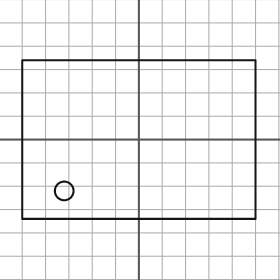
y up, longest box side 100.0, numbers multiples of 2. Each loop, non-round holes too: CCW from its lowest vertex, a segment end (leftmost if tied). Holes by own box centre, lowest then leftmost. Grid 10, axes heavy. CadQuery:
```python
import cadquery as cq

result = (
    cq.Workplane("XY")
    .moveTo(-50.0, -34.0)
    .lineTo(50.0, -34.0)
    .lineTo(50.0, 34.0)
    .lineTo(-50.0, 34.0)
    .close()
    .moveTo(-32.0, -22.0)
    .circle(4.0)
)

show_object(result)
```